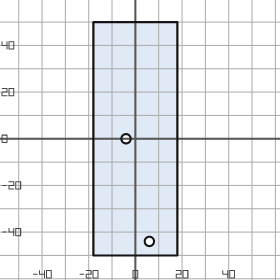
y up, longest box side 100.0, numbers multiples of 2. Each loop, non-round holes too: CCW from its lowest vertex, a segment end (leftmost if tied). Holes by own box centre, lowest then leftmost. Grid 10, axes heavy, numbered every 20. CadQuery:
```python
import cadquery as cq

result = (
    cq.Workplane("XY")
    .moveTo(-18.0, -50.0)
    .lineTo(18.0, -50.0)
    .lineTo(18.0, 50.0)
    .lineTo(-18.0, 50.0)
    .close()
    .moveTo(6.0, -44.0)
    .circle(2.0)
    .moveTo(-4.0, 0.0)
    .circle(2.0)
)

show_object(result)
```